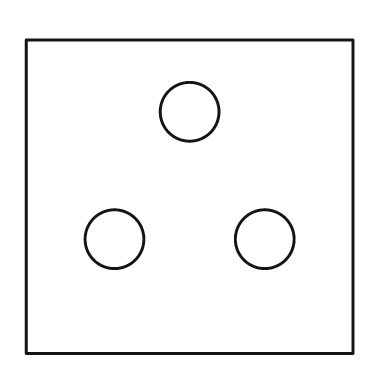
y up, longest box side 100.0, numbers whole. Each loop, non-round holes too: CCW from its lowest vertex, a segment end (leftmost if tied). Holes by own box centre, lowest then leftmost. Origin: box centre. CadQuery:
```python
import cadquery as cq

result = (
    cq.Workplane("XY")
    .moveTo(-50.0, -48.0)
    .lineTo(50.0, -48.0)
    .lineTo(50.0, 48.0)
    .lineTo(-50.0, 48.0)
    .close()
    .moveTo(-23.0, -13.0)
    .circle(9.0)
    .moveTo(23.0, -13.0)
    .circle(9.0)
    .moveTo(0.0, 26.0)
    .circle(9.0)
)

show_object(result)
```